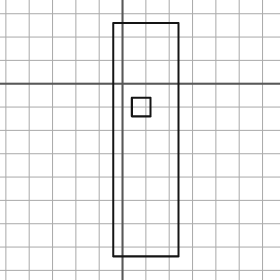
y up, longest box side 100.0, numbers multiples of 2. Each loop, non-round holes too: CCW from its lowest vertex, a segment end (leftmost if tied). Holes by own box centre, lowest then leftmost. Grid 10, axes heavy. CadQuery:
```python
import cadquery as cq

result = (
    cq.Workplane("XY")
    .moveTo(-4.0, -74.0)
    .lineTo(24.0, -74.0)
    .lineTo(24.0, 26.0)
    .lineTo(-4.0, 26.0)
    .close()
    .moveTo(4.0, -14.0)
    .lineTo(12.0, -14.0)
    .lineTo(12.0, -6.0)
    .lineTo(4.0, -6.0)
    .close()
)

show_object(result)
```